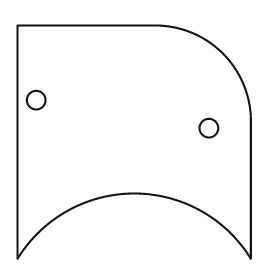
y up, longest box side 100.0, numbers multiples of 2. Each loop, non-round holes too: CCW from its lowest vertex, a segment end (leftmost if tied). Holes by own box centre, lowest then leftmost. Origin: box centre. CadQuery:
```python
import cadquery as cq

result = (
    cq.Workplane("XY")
    .moveTo(-50.0, -50.0)
    .threePointArc((0.0, -22.0), (50.0, -50.0))
    .lineTo(50.0, 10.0)
    .threePointArc((38.0, 38.0), (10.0, 50.0))
    .lineTo(-50.0, 50.0)
    .close()
    .moveTo(32.0, 6.0)
    .circle(4.0)
    .moveTo(-42.0, 18.0)
    .circle(4.0)
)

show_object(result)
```